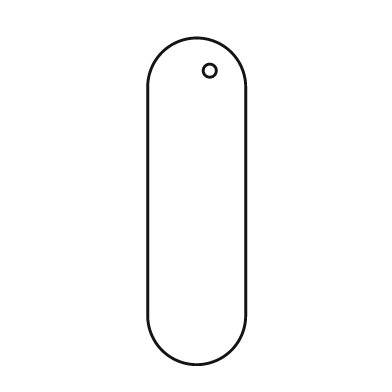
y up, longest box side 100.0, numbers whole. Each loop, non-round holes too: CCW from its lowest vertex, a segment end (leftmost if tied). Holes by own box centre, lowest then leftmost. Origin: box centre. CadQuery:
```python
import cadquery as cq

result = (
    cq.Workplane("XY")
    .moveTo(-15.0, -35.0)
    .threePointArc((0.0, -50.0), (15.0, -35.0))
    .lineTo(15.0, 35.0)
    .threePointArc((0.0, 50.0), (-15.0, 35.0))
    .close()
    .moveTo(4.0, 40.0)
    .circle(2.0)
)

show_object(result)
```